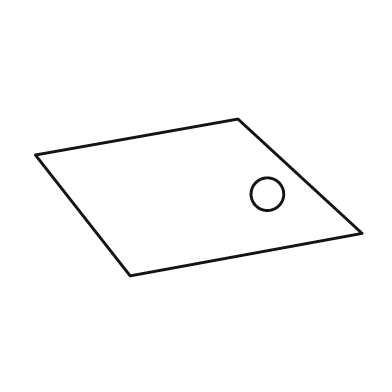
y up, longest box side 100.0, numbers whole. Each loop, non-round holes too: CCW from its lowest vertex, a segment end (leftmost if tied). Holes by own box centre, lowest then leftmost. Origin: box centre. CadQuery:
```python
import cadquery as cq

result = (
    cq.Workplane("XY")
    .moveTo(-21.0, -24.0)
    .lineTo(50.0, -11.0)
    .lineTo(12.0, 24.0)
    .lineTo(-50.0, 13.0)
    .close()
    .moveTo(21.0, 1.0)
    .circle(5.0)
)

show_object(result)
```